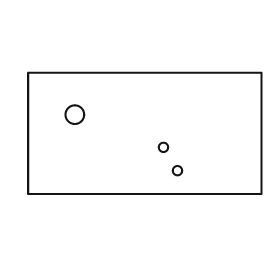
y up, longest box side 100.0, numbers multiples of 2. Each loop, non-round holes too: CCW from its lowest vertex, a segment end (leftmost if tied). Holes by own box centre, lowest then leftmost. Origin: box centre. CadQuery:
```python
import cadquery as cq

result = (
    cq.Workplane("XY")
    .moveTo(-50.0, -26.0)
    .lineTo(50.0, -26.0)
    .lineTo(50.0, 26.0)
    .lineTo(-50.0, 26.0)
    .close()
    .moveTo(14.0, -16.0)
    .circle(2.0)
    .moveTo(8.0, -6.0)
    .circle(2.0)
    .moveTo(-30.0, 8.0)
    .circle(4.0)
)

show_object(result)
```